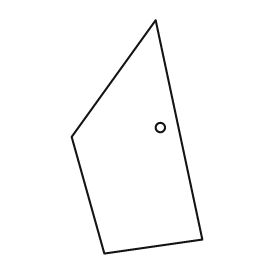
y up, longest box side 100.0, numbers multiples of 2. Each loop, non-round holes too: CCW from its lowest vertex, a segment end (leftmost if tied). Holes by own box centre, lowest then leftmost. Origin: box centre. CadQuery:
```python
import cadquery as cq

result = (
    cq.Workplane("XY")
    .moveTo(-14.0, -50.0)
    .lineTo(28.0, -44.0)
    .lineTo(8.0, 50.0)
    .lineTo(-28.0, 0.0)
    .close()
    .moveTo(10.0, 4.0)
    .circle(2.0)
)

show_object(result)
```